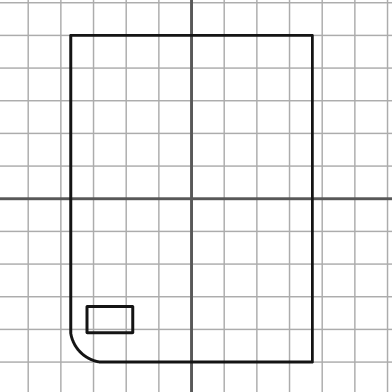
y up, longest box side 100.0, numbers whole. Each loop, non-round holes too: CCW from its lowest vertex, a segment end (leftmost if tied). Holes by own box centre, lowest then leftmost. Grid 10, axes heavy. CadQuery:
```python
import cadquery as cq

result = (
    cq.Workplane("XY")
    .moveTo(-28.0, -50.0)
    .lineTo(37.0, -50.0)
    .lineTo(37.0, 50.0)
    .lineTo(-37.0, 50.0)
    .lineTo(-37.0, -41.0)
    .threePointArc((-34.0, -47.0), (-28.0, -50.0))
    .close()
    .moveTo(-32.0, -41.0)
    .lineTo(-18.0, -41.0)
    .lineTo(-18.0, -33.0)
    .lineTo(-32.0, -33.0)
    .close()
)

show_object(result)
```